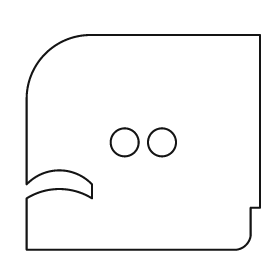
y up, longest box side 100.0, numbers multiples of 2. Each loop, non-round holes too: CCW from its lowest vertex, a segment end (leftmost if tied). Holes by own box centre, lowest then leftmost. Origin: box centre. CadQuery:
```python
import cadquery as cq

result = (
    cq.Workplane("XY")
    .moveTo(-50.0, -46.0)
    .lineTo(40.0, -46.0)
    .threePointArc((44.0, -44.0), (46.0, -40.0))
    .lineTo(46.0, -28.0)
    .lineTo(50.0, -28.0)
    .lineTo(50.0, 46.0)
    .lineTo(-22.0, 46.0)
    .threePointArc((-42.0, 38.0), (-50.0, 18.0))
    .lineTo(-50.0, -18.0)
    .threePointArc((-36.0, -12.0), (-22.0, -18.0))
    .lineTo(-22.0, -24.0)
    .threePointArc((-36.0, -20.0), (-50.0, -24.0))
    .close()
    .moveTo(-8.0, 0.0)
    .circle(6.0)
    .moveTo(8.0, 0.0)
    .circle(6.0)
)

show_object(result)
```